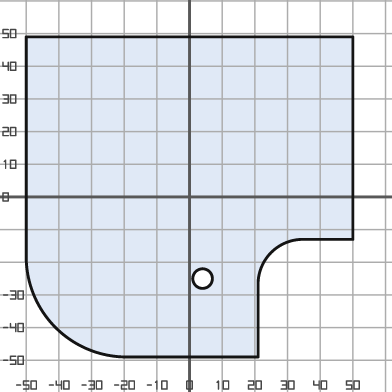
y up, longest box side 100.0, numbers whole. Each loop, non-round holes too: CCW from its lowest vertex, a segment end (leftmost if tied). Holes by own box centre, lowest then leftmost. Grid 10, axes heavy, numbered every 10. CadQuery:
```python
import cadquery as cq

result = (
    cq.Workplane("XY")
    .moveTo(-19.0, -49.0)
    .lineTo(21.0, -49.0)
    .lineTo(21.0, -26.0)
    .threePointArc((25.0, -17.0), (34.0, -13.0))
    .lineTo(50.0, -13.0)
    .lineTo(50.0, 49.0)
    .lineTo(-50.0, 49.0)
    .lineTo(-50.0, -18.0)
    .threePointArc((-41.0, -40.0), (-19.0, -49.0))
    .close()
    .moveTo(4.0, -25.0)
    .circle(3.0)
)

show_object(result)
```